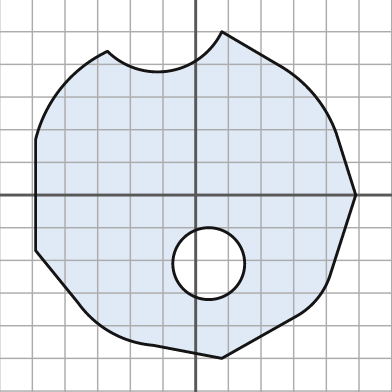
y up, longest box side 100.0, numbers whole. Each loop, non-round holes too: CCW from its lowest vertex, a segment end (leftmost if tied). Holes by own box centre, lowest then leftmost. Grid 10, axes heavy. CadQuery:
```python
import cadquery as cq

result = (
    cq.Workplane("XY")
    .moveTo(8.0, -50.0)
    .lineTo(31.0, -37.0)
    .threePointArc((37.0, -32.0), (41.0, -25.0))
    .lineTo(49.0, 0.0)
    .lineTo(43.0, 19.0)
    .threePointArc((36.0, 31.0), (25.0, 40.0))
    .lineTo(8.0, 50.0)
    .threePointArc((-8.0, 38.0), (-27.0, 44.0))
    .threePointArc((-41.0, 33.0), (-49.0, 17.0))
    .lineTo(-49.0, -17.0)
    .lineTo(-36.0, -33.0)
    .threePointArc((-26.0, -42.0), (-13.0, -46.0))
    .close()
    .moveTo(4.0, -21.0)
    .circle(11.0)
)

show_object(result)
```